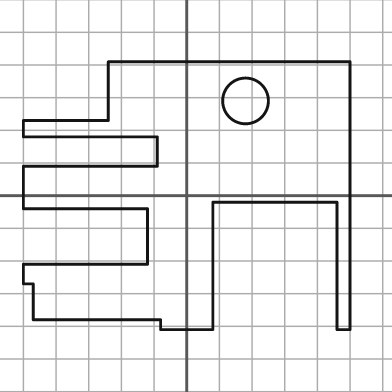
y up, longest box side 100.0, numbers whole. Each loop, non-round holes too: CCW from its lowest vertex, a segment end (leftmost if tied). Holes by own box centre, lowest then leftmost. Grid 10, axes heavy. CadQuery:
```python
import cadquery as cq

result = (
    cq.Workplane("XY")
    .moveTo(-8.0, -41.0)
    .lineTo(8.0, -41.0)
    .lineTo(8.0, -2.0)
    .lineTo(46.0, -2.0)
    .lineTo(46.0, -41.0)
    .lineTo(50.0, -41.0)
    .lineTo(50.0, 41.0)
    .lineTo(-24.0, 41.0)
    .lineTo(-24.0, 23.0)
    .lineTo(-50.0, 23.0)
    .lineTo(-50.0, 18.0)
    .lineTo(-9.0, 18.0)
    .lineTo(-9.0, 9.0)
    .lineTo(-50.0, 9.0)
    .lineTo(-50.0, -4.0)
    .lineTo(-12.0, -4.0)
    .lineTo(-12.0, -21.0)
    .lineTo(-50.0, -21.0)
    .lineTo(-50.0, -27.0)
    .lineTo(-47.0, -27.0)
    .lineTo(-47.0, -38.0)
    .lineTo(-8.0, -38.0)
    .close()
    .moveTo(18.0, 29.0)
    .circle(7.0)
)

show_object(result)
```